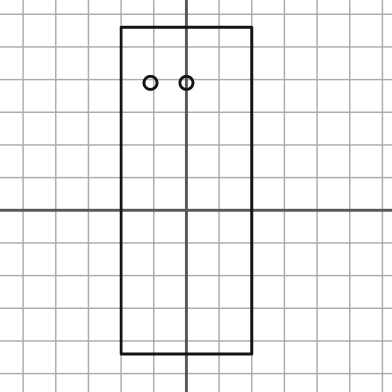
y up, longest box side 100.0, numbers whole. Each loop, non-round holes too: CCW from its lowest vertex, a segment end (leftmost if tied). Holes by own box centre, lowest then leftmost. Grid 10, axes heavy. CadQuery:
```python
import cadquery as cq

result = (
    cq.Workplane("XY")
    .moveTo(-20.0, -44.0)
    .lineTo(20.0, -44.0)
    .lineTo(20.0, 56.0)
    .lineTo(-20.0, 56.0)
    .close()
    .moveTo(-11.0, 39.0)
    .circle(2.0)
    .moveTo(0.0, 39.0)
    .circle(2.0)
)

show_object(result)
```